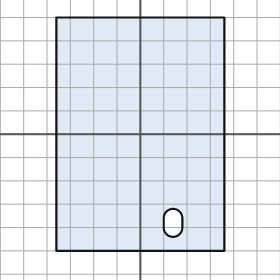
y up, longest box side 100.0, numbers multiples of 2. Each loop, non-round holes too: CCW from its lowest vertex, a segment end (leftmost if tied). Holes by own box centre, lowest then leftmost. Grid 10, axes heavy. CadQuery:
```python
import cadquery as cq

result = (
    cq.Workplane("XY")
    .moveTo(-36.0, -50.0)
    .lineTo(36.0, -50.0)
    .lineTo(36.0, 50.0)
    .lineTo(-36.0, 50.0)
    .close()
    .moveTo(10.0, -40.0)
    .threePointArc((14.0, -44.0), (18.0, -40.0))
    .lineTo(18.0, -36.0)
    .threePointArc((14.0, -32.0), (10.0, -36.0))
    .close()
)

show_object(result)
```